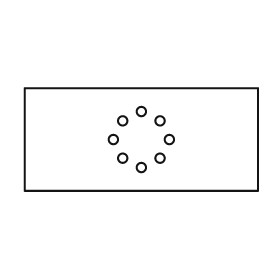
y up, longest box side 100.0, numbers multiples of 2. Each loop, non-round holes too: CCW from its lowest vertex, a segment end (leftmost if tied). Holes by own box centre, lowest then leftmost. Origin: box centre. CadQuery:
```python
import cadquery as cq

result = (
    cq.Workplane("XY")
    .moveTo(-50.0, -22.0)
    .lineTo(50.0, -22.0)
    .lineTo(50.0, 22.0)
    .lineTo(-50.0, 22.0)
    .close()
    .moveTo(0.0, -12.0)
    .circle(2.0)
    .moveTo(-8.0, -8.0)
    .circle(2.0)
    .moveTo(8.0, -8.0)
    .circle(2.0)
    .moveTo(-12.0, 0.0)
    .circle(2.0)
    .moveTo(12.0, 0.0)
    .circle(2.0)
    .moveTo(-8.0, 8.0)
    .circle(2.0)
    .moveTo(8.0, 8.0)
    .circle(2.0)
    .moveTo(0.0, 12.0)
    .circle(2.0)
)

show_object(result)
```